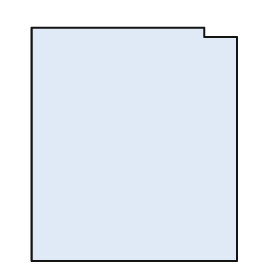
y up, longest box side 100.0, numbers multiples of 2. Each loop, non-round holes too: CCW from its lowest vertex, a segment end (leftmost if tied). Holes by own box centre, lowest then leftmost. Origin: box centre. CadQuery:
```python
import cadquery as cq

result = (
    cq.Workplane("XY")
    .moveTo(-44.0, -50.0)
    .lineTo(44.0, -50.0)
    .lineTo(44.0, 46.0)
    .lineTo(30.0, 46.0)
    .lineTo(30.0, 50.0)
    .lineTo(-44.0, 50.0)
    .close()
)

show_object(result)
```